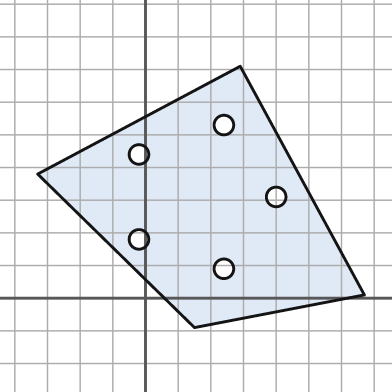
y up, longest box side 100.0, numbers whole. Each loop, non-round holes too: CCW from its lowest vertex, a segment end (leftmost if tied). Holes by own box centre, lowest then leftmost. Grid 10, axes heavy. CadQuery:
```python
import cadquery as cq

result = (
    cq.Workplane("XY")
    .moveTo(15.0, -9.0)
    .lineTo(67.0, 1.0)
    .lineTo(29.0, 71.0)
    .lineTo(-33.0, 38.0)
    .close()
    .moveTo(24.0, 9.0)
    .circle(3.0)
    .moveTo(-2.0, 18.0)
    .circle(3.0)
    .moveTo(40.0, 31.0)
    .circle(3.0)
    .moveTo(-2.0, 44.0)
    .circle(3.0)
    .moveTo(24.0, 53.0)
    .circle(3.0)
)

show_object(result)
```